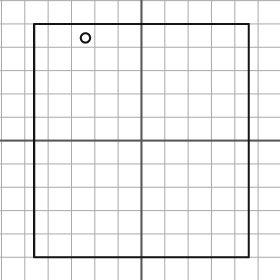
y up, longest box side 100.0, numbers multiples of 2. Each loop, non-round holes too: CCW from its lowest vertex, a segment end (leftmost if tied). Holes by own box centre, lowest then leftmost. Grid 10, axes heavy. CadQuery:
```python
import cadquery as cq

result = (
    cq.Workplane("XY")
    .moveTo(-46.0, -50.0)
    .lineTo(46.0, -50.0)
    .lineTo(46.0, 50.0)
    .lineTo(-46.0, 50.0)
    .close()
    .moveTo(-24.0, 44.0)
    .circle(2.0)
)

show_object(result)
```